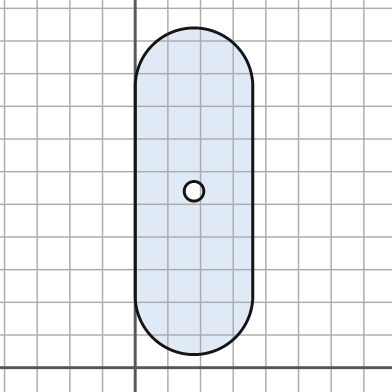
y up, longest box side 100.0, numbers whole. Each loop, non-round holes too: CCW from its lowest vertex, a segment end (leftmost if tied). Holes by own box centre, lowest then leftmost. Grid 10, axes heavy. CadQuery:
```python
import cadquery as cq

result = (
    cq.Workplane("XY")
    .moveTo(0.0, 22.0)
    .threePointArc((18.0, 4.0), (36.0, 22.0))
    .lineTo(36.0, 86.0)
    .threePointArc((18.0, 104.0), (0.0, 86.0))
    .close()
    .moveTo(18.0, 54.0)
    .circle(3.0)
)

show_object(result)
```